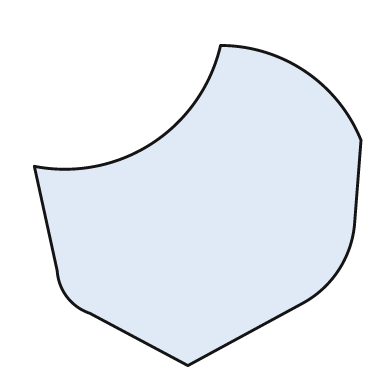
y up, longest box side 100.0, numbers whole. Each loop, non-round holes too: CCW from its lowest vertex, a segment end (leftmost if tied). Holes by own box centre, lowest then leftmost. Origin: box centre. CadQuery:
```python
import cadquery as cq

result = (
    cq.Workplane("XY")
    .moveTo(-3.0, -49.0)
    .lineTo(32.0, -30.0)
    .threePointArc((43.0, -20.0), (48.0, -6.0))
    .lineTo(50.0, 20.0)
    .threePointArc((33.0, 41.0), (7.0, 49.0))
    .threePointArc((-14.0, 19.0), (-50.0, 12.0))
    .lineTo(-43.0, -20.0)
    .threePointArc((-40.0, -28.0), (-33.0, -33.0))
    .close()
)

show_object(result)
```